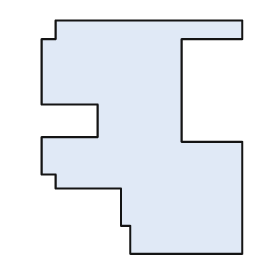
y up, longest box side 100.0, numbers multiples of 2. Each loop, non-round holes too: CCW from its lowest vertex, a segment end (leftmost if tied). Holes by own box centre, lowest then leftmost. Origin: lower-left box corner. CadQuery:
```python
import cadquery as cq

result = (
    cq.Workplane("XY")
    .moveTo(38.0, 0.0)
    .lineTo(86.0, 0.0)
    .lineTo(86.0, 48.0)
    .lineTo(60.0, 48.0)
    .lineTo(60.0, 92.0)
    .lineTo(86.0, 92.0)
    .lineTo(86.0, 100.0)
    .lineTo(6.0, 100.0)
    .lineTo(6.0, 92.0)
    .lineTo(0.0, 92.0)
    .lineTo(0.0, 64.0)
    .lineTo(24.0, 64.0)
    .lineTo(24.0, 50.0)
    .lineTo(0.0, 50.0)
    .lineTo(0.0, 34.0)
    .lineTo(6.0, 34.0)
    .lineTo(6.0, 28.0)
    .lineTo(34.0, 28.0)
    .lineTo(34.0, 12.0)
    .lineTo(38.0, 12.0)
    .close()
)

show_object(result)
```